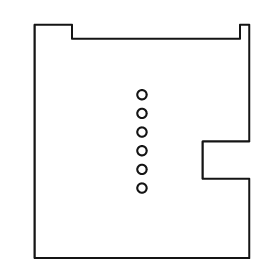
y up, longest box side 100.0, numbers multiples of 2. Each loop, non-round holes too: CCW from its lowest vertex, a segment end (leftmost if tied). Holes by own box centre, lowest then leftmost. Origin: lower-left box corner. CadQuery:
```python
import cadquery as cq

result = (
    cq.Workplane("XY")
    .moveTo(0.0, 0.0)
    .lineTo(92.0, 0.0)
    .lineTo(92.0, 34.0)
    .lineTo(72.0, 34.0)
    .lineTo(72.0, 50.0)
    .lineTo(92.0, 50.0)
    .lineTo(92.0, 100.0)
    .lineTo(88.0, 100.0)
    .lineTo(88.0, 94.0)
    .lineTo(16.0, 94.0)
    .lineTo(16.0, 100.0)
    .lineTo(0.0, 100.0)
    .close()
    .moveTo(46.0, 30.0)
    .circle(2.0)
    .moveTo(46.0, 38.0)
    .circle(2.0)
    .moveTo(46.0, 46.0)
    .circle(2.0)
    .moveTo(46.0, 54.0)
    .circle(2.0)
    .moveTo(46.0, 62.0)
    .circle(2.0)
    .moveTo(46.0, 70.0)
    .circle(2.0)
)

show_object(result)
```